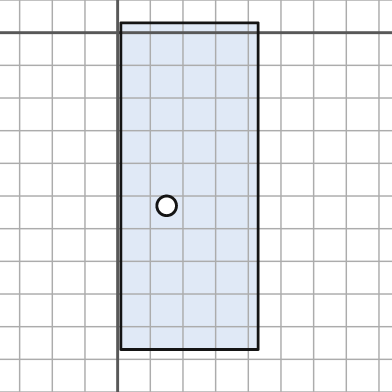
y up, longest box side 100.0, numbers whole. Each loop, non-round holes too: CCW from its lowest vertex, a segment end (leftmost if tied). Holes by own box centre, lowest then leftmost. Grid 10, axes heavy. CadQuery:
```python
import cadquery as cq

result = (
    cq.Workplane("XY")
    .moveTo(1.0, -97.0)
    .lineTo(43.0, -97.0)
    .lineTo(43.0, 3.0)
    .lineTo(1.0, 3.0)
    .close()
    .moveTo(15.0, -53.0)
    .circle(3.0)
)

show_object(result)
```